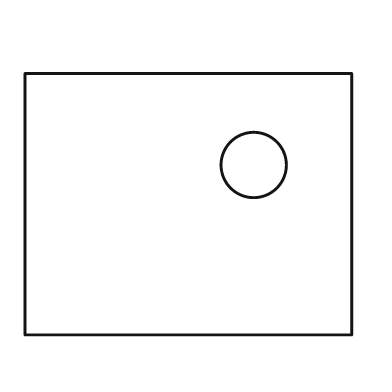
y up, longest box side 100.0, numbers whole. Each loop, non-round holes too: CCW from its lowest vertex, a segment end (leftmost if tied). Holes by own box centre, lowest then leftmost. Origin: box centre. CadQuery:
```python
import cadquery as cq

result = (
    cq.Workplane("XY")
    .moveTo(-50.0, -40.0)
    .lineTo(50.0, -40.0)
    .lineTo(50.0, 40.0)
    .lineTo(-50.0, 40.0)
    .close()
    .moveTo(20.0, 12.0)
    .circle(10.0)
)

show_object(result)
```